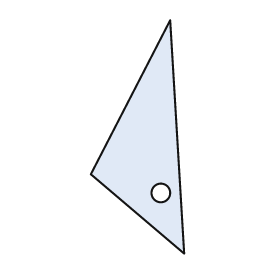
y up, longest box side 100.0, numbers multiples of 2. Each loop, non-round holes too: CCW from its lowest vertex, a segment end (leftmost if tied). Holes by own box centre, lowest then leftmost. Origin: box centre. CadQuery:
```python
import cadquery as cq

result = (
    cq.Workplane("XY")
    .moveTo(20.0, -50.0)
    .lineTo(14.0, 50.0)
    .lineTo(-20.0, -16.0)
    .close()
    .moveTo(10.0, -24.0)
    .circle(4.0)
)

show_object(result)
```